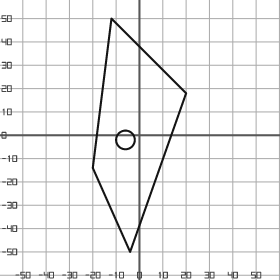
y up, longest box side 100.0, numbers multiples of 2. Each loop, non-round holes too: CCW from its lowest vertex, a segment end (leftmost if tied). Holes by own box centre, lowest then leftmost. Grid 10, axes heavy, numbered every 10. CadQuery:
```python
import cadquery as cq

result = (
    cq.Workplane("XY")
    .moveTo(-4.0, -50.0)
    .lineTo(20.0, 18.0)
    .lineTo(-12.0, 50.0)
    .lineTo(-20.0, -14.0)
    .close()
    .moveTo(-6.0, -2.0)
    .circle(4.0)
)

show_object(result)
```